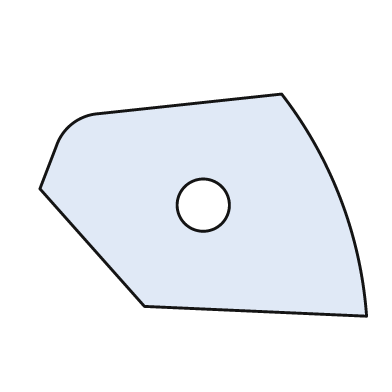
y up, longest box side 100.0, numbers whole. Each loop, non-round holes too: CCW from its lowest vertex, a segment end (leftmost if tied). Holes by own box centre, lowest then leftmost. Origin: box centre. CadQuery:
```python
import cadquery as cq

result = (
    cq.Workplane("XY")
    .moveTo(50.0, -34.0)
    .threePointArc((42.0, 2.0), (24.0, 34.0))
    .lineTo(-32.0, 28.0)
    .threePointArc((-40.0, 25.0), (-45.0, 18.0))
    .lineTo(-50.0, 5.0)
    .lineTo(-18.0, -31.0)
    .close()
    .moveTo(0.0, 0.0)
    .circle(8.0)
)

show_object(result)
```